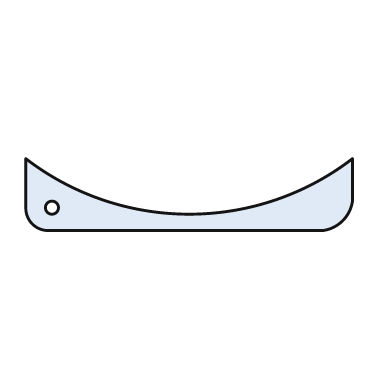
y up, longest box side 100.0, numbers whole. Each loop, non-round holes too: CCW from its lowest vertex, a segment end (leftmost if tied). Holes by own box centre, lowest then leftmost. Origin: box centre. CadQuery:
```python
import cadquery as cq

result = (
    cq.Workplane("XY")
    .moveTo(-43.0, -11.0)
    .lineTo(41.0, -11.0)
    .threePointArc((47.0, -8.0), (50.0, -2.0))
    .lineTo(50.0, 11.0)
    .threePointArc((0.0, -6.0), (-50.0, 11.0))
    .lineTo(-50.0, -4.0)
    .threePointArc((-48.0, -9.0), (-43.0, -11.0))
    .close()
    .moveTo(-42.0, -4.0)
    .circle(2.0)
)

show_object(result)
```